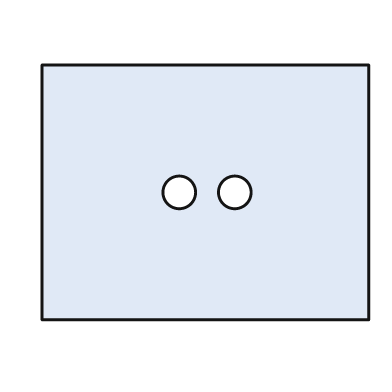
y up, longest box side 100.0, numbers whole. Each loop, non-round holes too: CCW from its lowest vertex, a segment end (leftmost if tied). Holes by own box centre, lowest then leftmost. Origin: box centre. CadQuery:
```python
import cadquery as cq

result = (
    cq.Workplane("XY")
    .moveTo(-50.0, -39.0)
    .lineTo(50.0, -39.0)
    .lineTo(50.0, 39.0)
    .lineTo(-50.0, 39.0)
    .close()
    .moveTo(-8.0, 0.0)
    .circle(5.0)
    .moveTo(9.0, 0.0)
    .circle(5.0)
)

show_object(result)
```